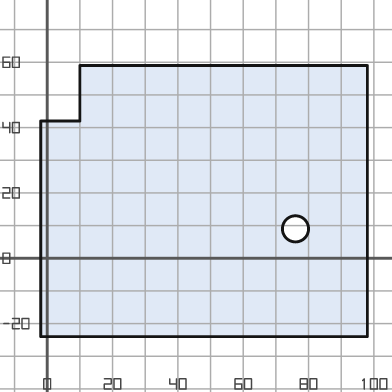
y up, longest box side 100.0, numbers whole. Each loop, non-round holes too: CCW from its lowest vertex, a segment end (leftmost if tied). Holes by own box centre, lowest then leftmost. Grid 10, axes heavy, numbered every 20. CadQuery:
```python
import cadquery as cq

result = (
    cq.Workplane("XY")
    .moveTo(-2.0, -24.0)
    .lineTo(98.0, -24.0)
    .lineTo(98.0, 59.0)
    .lineTo(10.0, 59.0)
    .lineTo(10.0, 42.0)
    .lineTo(-2.0, 42.0)
    .close()
    .moveTo(76.0, 9.0)
    .circle(4.0)
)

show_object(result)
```